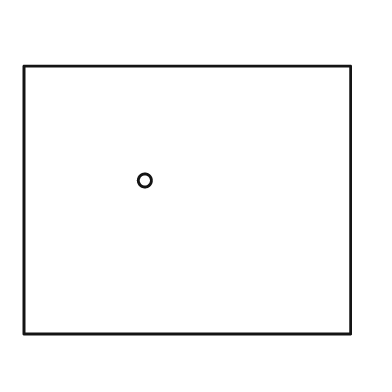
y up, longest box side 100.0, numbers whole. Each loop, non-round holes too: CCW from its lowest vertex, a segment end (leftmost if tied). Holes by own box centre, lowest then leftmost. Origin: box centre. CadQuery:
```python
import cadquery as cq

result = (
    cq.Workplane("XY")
    .moveTo(-50.0, -41.0)
    .lineTo(50.0, -41.0)
    .lineTo(50.0, 41.0)
    .lineTo(-50.0, 41.0)
    .close()
    .moveTo(-13.0, 6.0)
    .circle(2.0)
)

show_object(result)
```